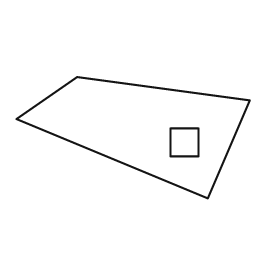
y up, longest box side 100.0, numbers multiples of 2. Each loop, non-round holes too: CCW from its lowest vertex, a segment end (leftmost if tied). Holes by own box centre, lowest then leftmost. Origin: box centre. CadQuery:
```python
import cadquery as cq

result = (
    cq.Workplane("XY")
    .moveTo(32.0, -26.0)
    .lineTo(50.0, 16.0)
    .lineTo(-24.0, 26.0)
    .lineTo(-50.0, 8.0)
    .close()
    .moveTo(16.0, -8.0)
    .lineTo(28.0, -8.0)
    .lineTo(28.0, 4.0)
    .lineTo(16.0, 4.0)
    .close()
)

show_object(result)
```